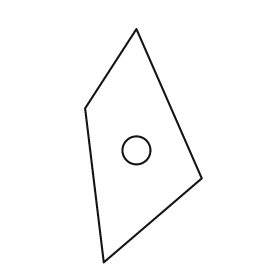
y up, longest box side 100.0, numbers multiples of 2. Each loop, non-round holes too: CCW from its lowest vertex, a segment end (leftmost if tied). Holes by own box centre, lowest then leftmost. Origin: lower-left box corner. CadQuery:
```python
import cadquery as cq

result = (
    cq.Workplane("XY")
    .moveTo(8.0, 0.0)
    .lineTo(50.0, 36.0)
    .lineTo(22.0, 100.0)
    .lineTo(0.0, 66.0)
    .close()
    .moveTo(22.0, 48.0)
    .circle(6.0)
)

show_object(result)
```